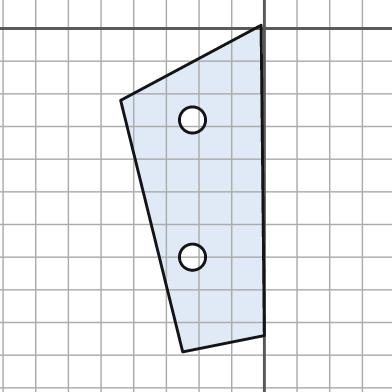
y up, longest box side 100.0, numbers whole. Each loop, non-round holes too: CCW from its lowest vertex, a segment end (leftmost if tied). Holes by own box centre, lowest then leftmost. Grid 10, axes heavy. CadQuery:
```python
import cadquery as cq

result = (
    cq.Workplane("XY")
    .moveTo(-25.0, -99.0)
    .lineTo(0.0, -94.0)
    .lineTo(-1.0, 1.0)
    .lineTo(-44.0, -22.0)
    .close()
    .moveTo(-22.0, -70.0)
    .circle(4.0)
    .moveTo(-22.0, -28.0)
    .circle(4.0)
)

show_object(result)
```